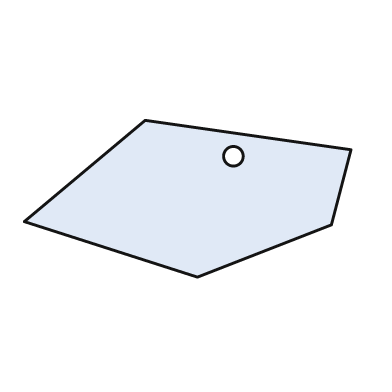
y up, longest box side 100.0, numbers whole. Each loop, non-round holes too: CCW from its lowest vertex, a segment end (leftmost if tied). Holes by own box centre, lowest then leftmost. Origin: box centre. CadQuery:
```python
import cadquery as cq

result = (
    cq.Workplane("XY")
    .moveTo(3.0, -24.0)
    .lineTo(44.0, -8.0)
    .lineTo(50.0, 15.0)
    .lineTo(-13.0, 24.0)
    .lineTo(-50.0, -7.0)
    .close()
    .moveTo(14.0, 13.0)
    .circle(3.0)
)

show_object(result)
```